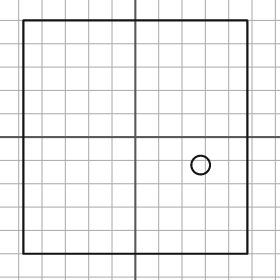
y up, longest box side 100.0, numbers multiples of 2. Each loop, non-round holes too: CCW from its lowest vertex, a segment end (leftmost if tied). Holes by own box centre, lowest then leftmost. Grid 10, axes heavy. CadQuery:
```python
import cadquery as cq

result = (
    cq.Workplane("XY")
    .moveTo(-48.0, -50.0)
    .lineTo(48.0, -50.0)
    .lineTo(48.0, 50.0)
    .lineTo(-48.0, 50.0)
    .close()
    .moveTo(28.0, -12.0)
    .circle(4.0)
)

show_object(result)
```